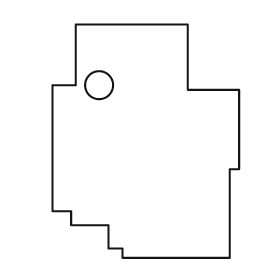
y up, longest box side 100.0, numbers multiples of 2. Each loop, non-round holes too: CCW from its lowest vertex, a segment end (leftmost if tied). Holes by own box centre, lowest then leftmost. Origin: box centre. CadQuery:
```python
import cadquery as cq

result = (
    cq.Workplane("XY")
    .moveTo(-10.0, -50.0)
    .lineTo(36.0, -50.0)
    .lineTo(36.0, -12.0)
    .lineTo(40.0, -12.0)
    .lineTo(40.0, 22.0)
    .lineTo(18.0, 22.0)
    .lineTo(18.0, 50.0)
    .lineTo(-30.0, 50.0)
    .lineTo(-30.0, 24.0)
    .lineTo(-40.0, 24.0)
    .lineTo(-40.0, -30.0)
    .lineTo(-32.0, -30.0)
    .lineTo(-32.0, -36.0)
    .lineTo(-16.0, -36.0)
    .lineTo(-16.0, -46.0)
    .lineTo(-10.0, -46.0)
    .close()
    .moveTo(-20.0, 24.0)
    .circle(6.0)
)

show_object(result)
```